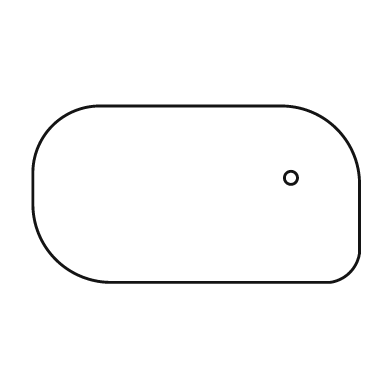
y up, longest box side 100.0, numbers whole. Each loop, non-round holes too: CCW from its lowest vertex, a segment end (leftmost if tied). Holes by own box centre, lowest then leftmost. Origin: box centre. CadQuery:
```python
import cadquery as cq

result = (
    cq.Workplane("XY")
    .moveTo(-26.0, -27.0)
    .lineTo(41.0, -27.0)
    .threePointArc((47.0, -24.0), (50.0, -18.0))
    .lineTo(50.0, 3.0)
    .threePointArc((43.0, 20.0), (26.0, 27.0))
    .lineTo(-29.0, 27.0)
    .threePointArc((-44.0, 21.0), (-50.0, 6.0))
    .lineTo(-50.0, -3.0)
    .threePointArc((-43.0, -20.0), (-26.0, -27.0))
    .close()
    .moveTo(29.0, 5.0)
    .circle(2.0)
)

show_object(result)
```